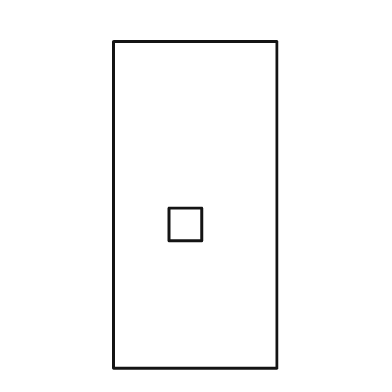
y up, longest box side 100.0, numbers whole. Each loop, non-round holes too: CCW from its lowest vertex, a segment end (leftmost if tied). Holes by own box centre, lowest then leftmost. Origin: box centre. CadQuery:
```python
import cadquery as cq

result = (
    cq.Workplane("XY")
    .moveTo(-25.0, -50.0)
    .lineTo(25.0, -50.0)
    .lineTo(25.0, 50.0)
    .lineTo(-25.0, 50.0)
    .close()
    .moveTo(-8.0, -11.0)
    .lineTo(2.0, -11.0)
    .lineTo(2.0, -1.0)
    .lineTo(-8.0, -1.0)
    .close()
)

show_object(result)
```